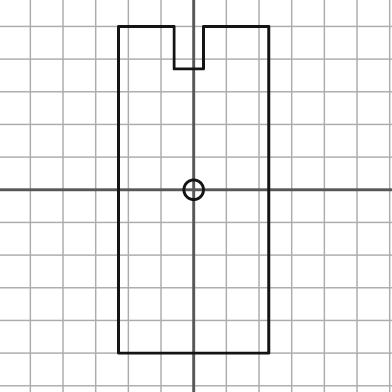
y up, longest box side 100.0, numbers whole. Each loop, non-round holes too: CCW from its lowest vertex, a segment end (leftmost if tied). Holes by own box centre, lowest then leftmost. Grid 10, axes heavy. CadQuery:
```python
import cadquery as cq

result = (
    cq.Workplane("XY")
    .moveTo(-23.0, -50.0)
    .lineTo(23.0, -50.0)
    .lineTo(23.0, 50.0)
    .lineTo(3.0, 50.0)
    .lineTo(3.0, 37.0)
    .lineTo(-6.0, 37.0)
    .lineTo(-6.0, 50.0)
    .lineTo(-23.0, 50.0)
    .close()
    .moveTo(0.0, 0.0)
    .circle(3.0)
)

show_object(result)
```